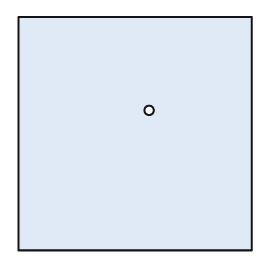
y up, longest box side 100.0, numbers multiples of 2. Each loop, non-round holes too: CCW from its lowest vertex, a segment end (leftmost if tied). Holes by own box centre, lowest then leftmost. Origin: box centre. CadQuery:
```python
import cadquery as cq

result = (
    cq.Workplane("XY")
    .moveTo(-50.0, -50.0)
    .lineTo(50.0, -50.0)
    .lineTo(50.0, 50.0)
    .lineTo(-50.0, 50.0)
    .close()
    .moveTo(6.0, 10.0)
    .circle(2.0)
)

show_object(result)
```